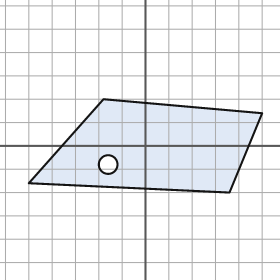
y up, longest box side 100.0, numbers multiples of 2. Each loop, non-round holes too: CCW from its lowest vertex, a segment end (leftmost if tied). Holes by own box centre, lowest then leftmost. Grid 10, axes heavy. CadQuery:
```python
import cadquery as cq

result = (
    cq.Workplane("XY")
    .moveTo(36.0, -20.0)
    .lineTo(50.0, 14.0)
    .lineTo(-18.0, 20.0)
    .lineTo(-50.0, -16.0)
    .close()
    .moveTo(-16.0, -8.0)
    .circle(4.0)
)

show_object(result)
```